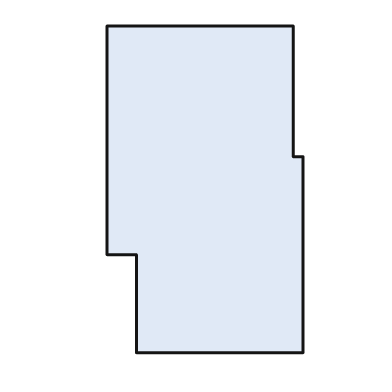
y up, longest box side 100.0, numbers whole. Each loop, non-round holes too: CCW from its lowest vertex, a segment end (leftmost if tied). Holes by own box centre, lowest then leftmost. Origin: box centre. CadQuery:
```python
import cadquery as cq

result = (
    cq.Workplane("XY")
    .moveTo(-21.0, -50.0)
    .lineTo(30.0, -50.0)
    .lineTo(30.0, 10.0)
    .lineTo(27.0, 10.0)
    .lineTo(27.0, 50.0)
    .lineTo(-30.0, 50.0)
    .lineTo(-30.0, -20.0)
    .lineTo(-21.0, -20.0)
    .close()
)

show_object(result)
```